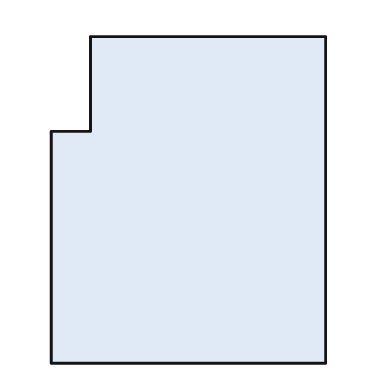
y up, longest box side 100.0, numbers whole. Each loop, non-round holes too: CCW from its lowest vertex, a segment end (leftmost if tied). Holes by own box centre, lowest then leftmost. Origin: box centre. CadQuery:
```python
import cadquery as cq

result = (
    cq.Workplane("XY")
    .moveTo(-42.0, -50.0)
    .lineTo(42.0, -50.0)
    .lineTo(42.0, 50.0)
    .lineTo(-30.0, 50.0)
    .lineTo(-30.0, 21.0)
    .lineTo(-42.0, 21.0)
    .close()
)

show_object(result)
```